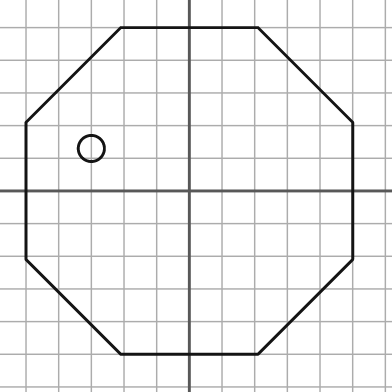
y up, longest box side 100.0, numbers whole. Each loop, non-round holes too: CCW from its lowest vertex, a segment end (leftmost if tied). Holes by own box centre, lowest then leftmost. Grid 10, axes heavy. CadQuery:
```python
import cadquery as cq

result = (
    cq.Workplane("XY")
    .moveTo(-21.0, -50.0)
    .lineTo(21.0, -50.0)
    .lineTo(50.0, -21.0)
    .lineTo(50.0, 21.0)
    .lineTo(21.0, 50.0)
    .lineTo(-21.0, 50.0)
    .lineTo(-50.0, 21.0)
    .lineTo(-50.0, -21.0)
    .close()
    .moveTo(-30.0, 13.0)
    .circle(4.0)
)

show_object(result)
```